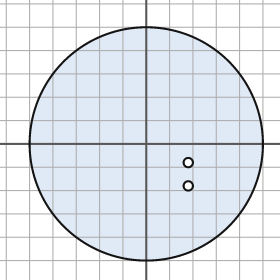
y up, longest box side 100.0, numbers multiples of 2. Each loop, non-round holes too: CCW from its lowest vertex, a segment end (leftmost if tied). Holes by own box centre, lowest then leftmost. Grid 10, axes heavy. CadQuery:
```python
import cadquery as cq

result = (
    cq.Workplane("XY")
    .moveTo(0.0, 0.0)
    .circle(50.0)
    .moveTo(18.0, -18.0)
    .circle(2.0)
    .moveTo(18.0, -8.0)
    .circle(2.0)
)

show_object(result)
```